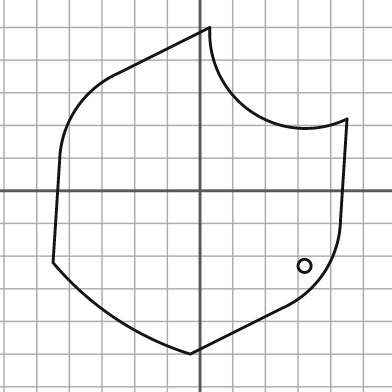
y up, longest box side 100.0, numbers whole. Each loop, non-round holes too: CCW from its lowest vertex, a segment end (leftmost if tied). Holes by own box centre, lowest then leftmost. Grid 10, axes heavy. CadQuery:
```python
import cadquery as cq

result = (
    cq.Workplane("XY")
    .moveTo(-3.0, -50.0)
    .lineTo(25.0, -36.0)
    .threePointArc((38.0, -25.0), (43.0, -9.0))
    .lineTo(45.0, 22.0)
    .threePointArc((16.0, 24.0), (3.0, 50.0))
    .lineTo(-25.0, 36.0)
    .threePointArc((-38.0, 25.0), (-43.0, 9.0))
    .lineTo(-45.0, -22.0)
    .threePointArc((-26.0, -39.0), (-3.0, -50.0))
    .close()
    .moveTo(32.0, -23.0)
    .circle(2.0)
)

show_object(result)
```